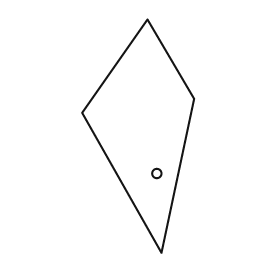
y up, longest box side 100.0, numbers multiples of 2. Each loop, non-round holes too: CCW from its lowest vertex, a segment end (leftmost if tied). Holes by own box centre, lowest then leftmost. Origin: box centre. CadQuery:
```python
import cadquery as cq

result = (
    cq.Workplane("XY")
    .moveTo(10.0, -50.0)
    .lineTo(24.0, 16.0)
    .lineTo(4.0, 50.0)
    .lineTo(-24.0, 10.0)
    .close()
    .moveTo(8.0, -16.0)
    .circle(2.0)
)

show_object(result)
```